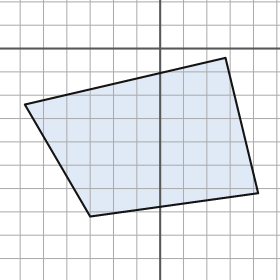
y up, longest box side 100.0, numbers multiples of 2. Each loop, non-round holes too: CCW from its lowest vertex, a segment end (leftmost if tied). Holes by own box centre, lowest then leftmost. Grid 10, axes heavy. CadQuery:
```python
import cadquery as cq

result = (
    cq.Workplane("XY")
    .moveTo(-30.0, -72.0)
    .lineTo(42.0, -62.0)
    .lineTo(28.0, -4.0)
    .lineTo(-58.0, -24.0)
    .close()
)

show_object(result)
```